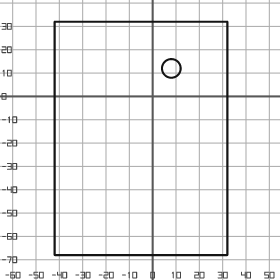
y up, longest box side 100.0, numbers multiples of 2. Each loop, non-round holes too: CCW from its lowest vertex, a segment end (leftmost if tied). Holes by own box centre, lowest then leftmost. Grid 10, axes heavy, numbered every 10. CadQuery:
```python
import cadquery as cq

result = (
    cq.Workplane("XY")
    .moveTo(-42.0, -68.0)
    .lineTo(32.0, -68.0)
    .lineTo(32.0, 32.0)
    .lineTo(-42.0, 32.0)
    .close()
    .moveTo(8.0, 12.0)
    .circle(4.0)
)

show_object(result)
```